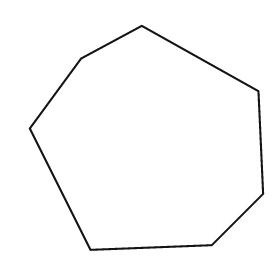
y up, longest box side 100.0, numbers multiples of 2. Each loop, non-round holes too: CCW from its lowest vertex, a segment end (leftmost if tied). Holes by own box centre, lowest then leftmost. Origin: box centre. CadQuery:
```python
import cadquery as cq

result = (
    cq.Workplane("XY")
    .moveTo(-24.0, -48.0)
    .lineTo(28.0, -46.0)
    .lineTo(50.0, -24.0)
    .lineTo(48.0, 20.0)
    .lineTo(-2.0, 48.0)
    .lineTo(-28.0, 34.0)
    .lineTo(-50.0, 4.0)
    .close()
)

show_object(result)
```